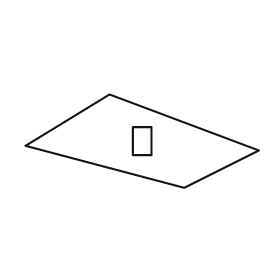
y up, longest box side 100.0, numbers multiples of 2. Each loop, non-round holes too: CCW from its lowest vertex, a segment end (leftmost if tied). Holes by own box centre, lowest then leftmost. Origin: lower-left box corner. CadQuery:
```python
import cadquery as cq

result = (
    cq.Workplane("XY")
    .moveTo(68.0, 0.0)
    .lineTo(100.0, 16.0)
    .lineTo(36.0, 40.0)
    .lineTo(0.0, 18.0)
    .close()
    .moveTo(46.0, 14.0)
    .lineTo(54.0, 14.0)
    .lineTo(54.0, 26.0)
    .lineTo(46.0, 26.0)
    .close()
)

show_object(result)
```